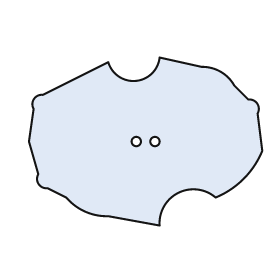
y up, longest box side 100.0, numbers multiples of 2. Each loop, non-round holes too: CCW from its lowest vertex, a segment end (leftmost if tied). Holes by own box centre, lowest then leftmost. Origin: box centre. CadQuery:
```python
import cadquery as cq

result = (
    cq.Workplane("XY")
    .moveTo(6.0, -36.0)
    .threePointArc((14.0, -22.0), (30.0, -24.0))
    .threePointArc((42.0, -16.0), (50.0, -4.0))
    .lineTo(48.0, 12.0)
    .threePointArc((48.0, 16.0), (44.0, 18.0))
    .lineTo(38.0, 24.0)
    .threePointArc((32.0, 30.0), (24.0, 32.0))
    .lineTo(6.0, 36.0)
    .threePointArc((-4.0, 26.0), (-16.0, 34.0))
    .lineTo(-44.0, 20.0)
    .threePointArc((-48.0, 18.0), (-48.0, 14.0))
    .lineTo(-50.0, 0.0)
    .lineTo(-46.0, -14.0)
    .threePointArc((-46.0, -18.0), (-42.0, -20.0))
    .lineTo(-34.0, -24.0)
    .threePointArc((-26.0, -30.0), (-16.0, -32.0))
    .close()
    .moveTo(-4.0, 0.0)
    .circle(2.0)
    .moveTo(4.0, 0.0)
    .circle(2.0)
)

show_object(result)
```